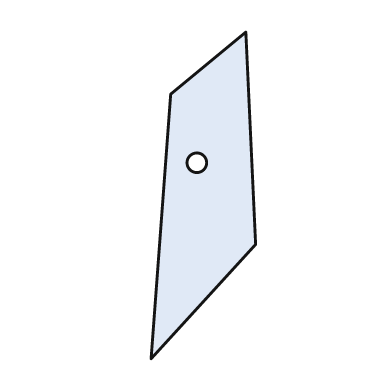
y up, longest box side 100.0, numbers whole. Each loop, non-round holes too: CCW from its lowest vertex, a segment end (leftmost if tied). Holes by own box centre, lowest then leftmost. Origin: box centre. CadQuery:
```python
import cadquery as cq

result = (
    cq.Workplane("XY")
    .moveTo(-16.0, -50.0)
    .lineTo(16.0, -15.0)
    .lineTo(13.0, 50.0)
    .lineTo(-10.0, 31.0)
    .close()
    .moveTo(-2.0, 10.0)
    .circle(3.0)
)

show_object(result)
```